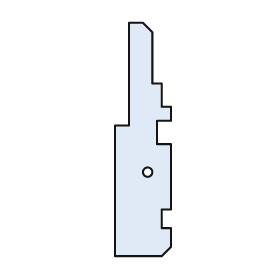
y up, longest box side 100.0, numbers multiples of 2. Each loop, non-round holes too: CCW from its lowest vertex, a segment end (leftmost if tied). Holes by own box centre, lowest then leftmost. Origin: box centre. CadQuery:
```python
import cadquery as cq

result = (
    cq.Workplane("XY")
    .moveTo(-12.0, -50.0)
    .lineTo(8.0, -50.0)
    .lineTo(12.0, -46.0)
    .lineTo(12.0, -38.0)
    .lineTo(8.0, -38.0)
    .lineTo(8.0, -30.0)
    .lineTo(12.0, -30.0)
    .lineTo(12.0, -2.0)
    .lineTo(6.0, -2.0)
    .lineTo(6.0, 8.0)
    .lineTo(12.0, 8.0)
    .lineTo(12.0, 14.0)
    .lineTo(8.0, 14.0)
    .lineTo(8.0, 24.0)
    .lineTo(4.0, 24.0)
    .lineTo(4.0, 46.0)
    .lineTo(0.0, 50.0)
    .lineTo(-6.0, 50.0)
    .lineTo(-6.0, 6.0)
    .lineTo(-12.0, 6.0)
    .close()
    .moveTo(2.0, -14.0)
    .circle(2.0)
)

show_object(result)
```